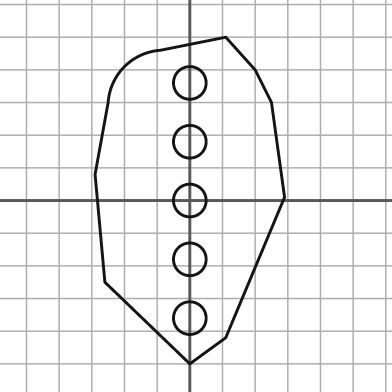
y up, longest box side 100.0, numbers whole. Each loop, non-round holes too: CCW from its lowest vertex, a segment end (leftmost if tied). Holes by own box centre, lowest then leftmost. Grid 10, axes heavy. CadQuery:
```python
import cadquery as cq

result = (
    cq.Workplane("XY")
    .moveTo(0.0, -50.0)
    .lineTo(11.0, -42.0)
    .lineTo(29.0, 1.0)
    .lineTo(25.0, 30.0)
    .lineTo(20.0, 40.0)
    .lineTo(11.0, 50.0)
    .lineTo(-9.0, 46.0)
    .threePointArc((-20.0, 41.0), (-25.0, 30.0))
    .lineTo(-29.0, 8.0)
    .lineTo(-26.0, -25.0)
    .close()
    .moveTo(0.0, -36.0)
    .circle(5.0)
    .moveTo(0.0, -18.0)
    .circle(5.0)
    .moveTo(0.0, 0.0)
    .circle(5.0)
    .moveTo(0.0, 18.0)
    .circle(5.0)
    .moveTo(0.0, 36.0)
    .circle(5.0)
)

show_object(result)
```